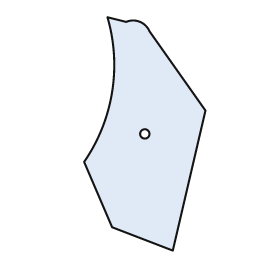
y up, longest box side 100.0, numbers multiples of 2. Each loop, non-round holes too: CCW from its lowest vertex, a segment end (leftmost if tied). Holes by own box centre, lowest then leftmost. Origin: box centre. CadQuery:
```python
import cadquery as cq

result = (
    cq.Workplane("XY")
    .moveTo(12.0, -50.0)
    .lineTo(26.0, 10.0)
    .lineTo(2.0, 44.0)
    .threePointArc((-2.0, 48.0), (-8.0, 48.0))
    .lineTo(-16.0, 50.0)
    .threePointArc((-14.0, 18.0), (-26.0, -12.0))
    .lineTo(-14.0, -40.0)
    .close()
    .moveTo(0.0, 0.0)
    .circle(2.0)
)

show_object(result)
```